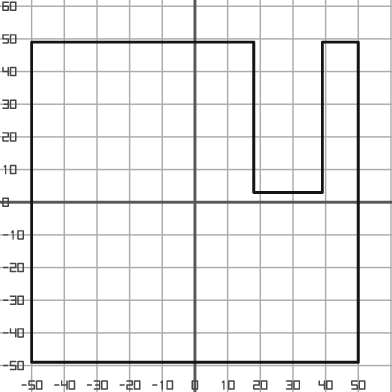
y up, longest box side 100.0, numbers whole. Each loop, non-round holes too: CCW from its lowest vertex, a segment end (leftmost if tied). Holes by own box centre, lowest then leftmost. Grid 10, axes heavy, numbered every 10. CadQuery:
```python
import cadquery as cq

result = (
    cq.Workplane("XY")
    .moveTo(-50.0, -49.0)
    .lineTo(50.0, -49.0)
    .lineTo(50.0, 49.0)
    .lineTo(39.0, 49.0)
    .lineTo(39.0, 3.0)
    .lineTo(18.0, 3.0)
    .lineTo(18.0, 49.0)
    .lineTo(-50.0, 49.0)
    .close()
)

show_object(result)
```